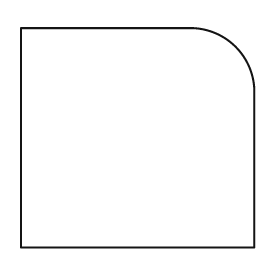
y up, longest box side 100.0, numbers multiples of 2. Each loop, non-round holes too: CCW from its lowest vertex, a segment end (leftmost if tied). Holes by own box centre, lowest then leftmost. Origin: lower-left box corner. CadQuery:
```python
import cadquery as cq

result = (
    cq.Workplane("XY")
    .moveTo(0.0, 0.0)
    .lineTo(100.0, 0.0)
    .lineTo(100.0, 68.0)
    .threePointArc((92.0, 86.0), (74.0, 94.0))
    .lineTo(0.0, 94.0)
    .close()
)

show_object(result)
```